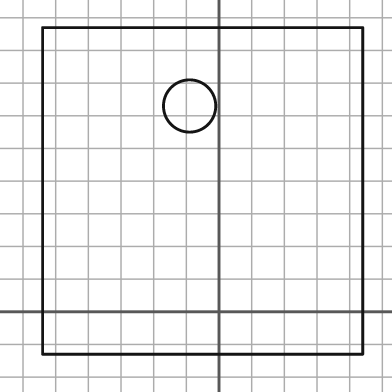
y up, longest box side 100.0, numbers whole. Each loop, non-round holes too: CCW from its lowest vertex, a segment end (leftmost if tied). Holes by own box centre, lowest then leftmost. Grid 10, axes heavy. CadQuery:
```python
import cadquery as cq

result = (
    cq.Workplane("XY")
    .moveTo(-54.0, -13.0)
    .lineTo(44.0, -13.0)
    .lineTo(44.0, 87.0)
    .lineTo(-54.0, 87.0)
    .close()
    .moveTo(-9.0, 63.0)
    .circle(8.0)
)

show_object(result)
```